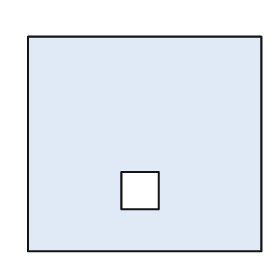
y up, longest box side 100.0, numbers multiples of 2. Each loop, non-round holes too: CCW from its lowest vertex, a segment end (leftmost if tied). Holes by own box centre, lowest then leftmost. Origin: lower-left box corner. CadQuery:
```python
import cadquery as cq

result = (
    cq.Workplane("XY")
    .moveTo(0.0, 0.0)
    .lineTo(100.0, 0.0)
    .lineTo(100.0, 92.0)
    .lineTo(0.0, 92.0)
    .close()
    .moveTo(40.0, 18.0)
    .lineTo(56.0, 18.0)
    .lineTo(56.0, 34.0)
    .lineTo(40.0, 34.0)
    .close()
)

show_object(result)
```